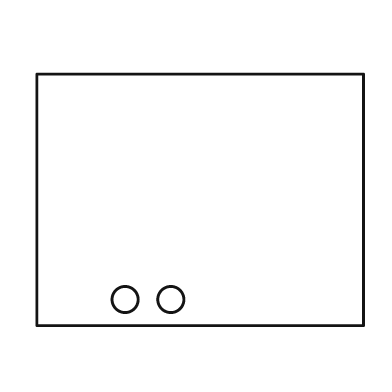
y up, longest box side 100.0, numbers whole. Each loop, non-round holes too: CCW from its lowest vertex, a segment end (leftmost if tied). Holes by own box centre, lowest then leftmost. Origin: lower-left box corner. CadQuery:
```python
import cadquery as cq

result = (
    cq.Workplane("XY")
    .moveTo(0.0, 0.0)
    .lineTo(100.0, 0.0)
    .lineTo(100.0, 77.0)
    .lineTo(0.0, 77.0)
    .close()
    .moveTo(27.0, 8.0)
    .circle(4.0)
    .moveTo(41.0, 8.0)
    .circle(4.0)
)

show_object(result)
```